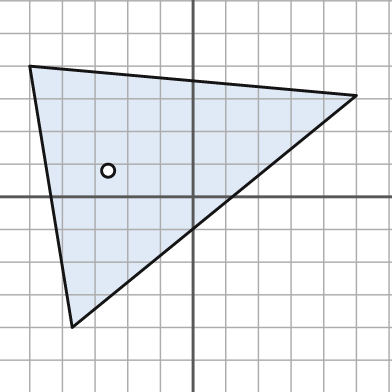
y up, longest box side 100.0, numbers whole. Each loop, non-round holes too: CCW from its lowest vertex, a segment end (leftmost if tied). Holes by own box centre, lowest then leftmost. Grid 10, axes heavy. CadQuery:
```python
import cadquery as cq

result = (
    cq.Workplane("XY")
    .moveTo(-37.0, -40.0)
    .lineTo(50.0, 31.0)
    .lineTo(-50.0, 40.0)
    .close()
    .moveTo(-26.0, 8.0)
    .circle(2.0)
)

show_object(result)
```